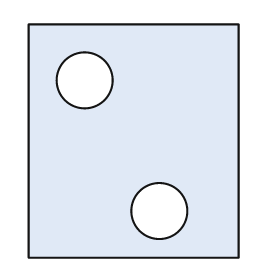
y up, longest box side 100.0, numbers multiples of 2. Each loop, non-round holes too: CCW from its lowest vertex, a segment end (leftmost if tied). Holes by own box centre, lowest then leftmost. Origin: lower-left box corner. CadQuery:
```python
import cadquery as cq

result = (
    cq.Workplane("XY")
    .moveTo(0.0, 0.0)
    .lineTo(90.0, 0.0)
    .lineTo(90.0, 100.0)
    .lineTo(0.0, 100.0)
    .close()
    .moveTo(56.0, 20.0)
    .circle(12.0)
    .moveTo(24.0, 76.0)
    .circle(12.0)
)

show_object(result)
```